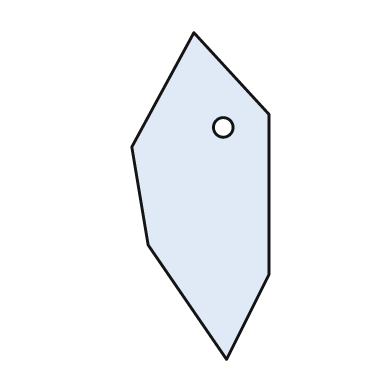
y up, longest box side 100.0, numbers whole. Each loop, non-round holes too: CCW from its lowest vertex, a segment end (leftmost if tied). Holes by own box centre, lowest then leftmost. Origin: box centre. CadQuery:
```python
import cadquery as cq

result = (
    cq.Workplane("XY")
    .moveTo(8.0, -50.0)
    .lineTo(21.0, -24.0)
    .lineTo(21.0, 25.0)
    .lineTo(-2.0, 50.0)
    .lineTo(-21.0, 15.0)
    .lineTo(-16.0, -15.0)
    .close()
    .moveTo(7.0, 21.0)
    .circle(3.0)
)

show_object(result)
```